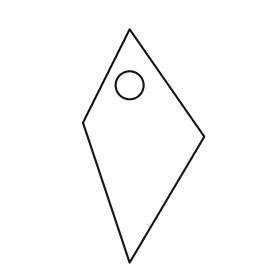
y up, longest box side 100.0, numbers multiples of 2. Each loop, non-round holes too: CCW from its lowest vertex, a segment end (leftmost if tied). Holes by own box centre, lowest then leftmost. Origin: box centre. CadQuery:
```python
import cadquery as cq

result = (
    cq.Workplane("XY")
    .moveTo(-6.0, -50.0)
    .lineTo(26.0, 4.0)
    .lineTo(-6.0, 50.0)
    .lineTo(-26.0, 10.0)
    .close()
    .moveTo(-6.0, 26.0)
    .circle(6.0)
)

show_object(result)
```